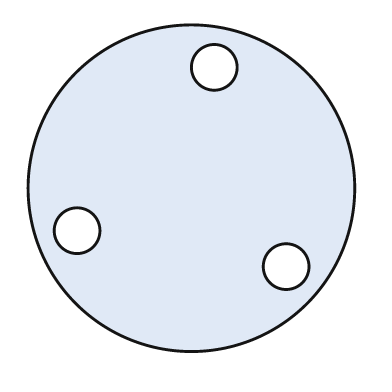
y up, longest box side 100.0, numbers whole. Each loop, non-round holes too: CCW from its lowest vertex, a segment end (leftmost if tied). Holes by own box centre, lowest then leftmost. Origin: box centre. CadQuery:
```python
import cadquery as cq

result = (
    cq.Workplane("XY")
    .moveTo(0.0, 0.0)
    .circle(50.0)
    .moveTo(29.0, -24.0)
    .circle(7.0)
    .moveTo(-35.0, -13.0)
    .circle(7.0)
    .moveTo(7.0, 37.0)
    .circle(7.0)
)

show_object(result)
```